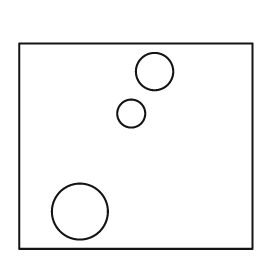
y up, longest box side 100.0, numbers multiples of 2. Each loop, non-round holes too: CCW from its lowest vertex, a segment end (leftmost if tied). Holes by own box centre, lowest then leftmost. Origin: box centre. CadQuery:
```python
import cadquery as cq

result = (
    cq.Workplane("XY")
    .moveTo(-50.0, -44.0)
    .lineTo(50.0, -44.0)
    .lineTo(50.0, 44.0)
    .lineTo(-50.0, 44.0)
    .close()
    .moveTo(-24.0, -28.0)
    .circle(12.0)
    .moveTo(-2.0, 14.0)
    .circle(6.0)
    .moveTo(8.0, 32.0)
    .circle(8.0)
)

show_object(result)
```